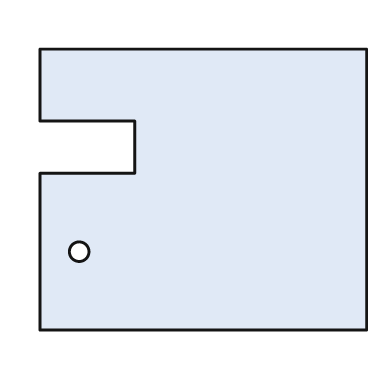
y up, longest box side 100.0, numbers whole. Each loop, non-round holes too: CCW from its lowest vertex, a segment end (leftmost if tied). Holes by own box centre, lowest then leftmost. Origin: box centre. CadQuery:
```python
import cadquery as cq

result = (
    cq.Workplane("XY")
    .moveTo(-50.0, -43.0)
    .lineTo(50.0, -43.0)
    .lineTo(50.0, 43.0)
    .lineTo(-50.0, 43.0)
    .lineTo(-50.0, 21.0)
    .lineTo(-21.0, 21.0)
    .lineTo(-21.0, 5.0)
    .lineTo(-50.0, 5.0)
    .close()
    .moveTo(-38.0, -19.0)
    .circle(3.0)
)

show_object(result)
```